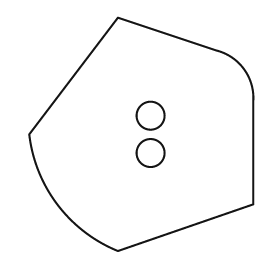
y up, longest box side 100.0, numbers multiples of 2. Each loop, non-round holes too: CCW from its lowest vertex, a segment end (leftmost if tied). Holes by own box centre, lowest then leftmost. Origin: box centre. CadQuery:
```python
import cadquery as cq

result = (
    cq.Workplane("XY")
    .moveTo(-10.0, -50.0)
    .lineTo(48.0, -30.0)
    .lineTo(48.0, 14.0)
    .threePointArc((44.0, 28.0), (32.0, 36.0))
    .lineTo(-10.0, 50.0)
    .lineTo(-48.0, 0.0)
    .threePointArc((-36.0, -30.0), (-10.0, -50.0))
    .close()
    .moveTo(4.0, -8.0)
    .circle(6.0)
    .moveTo(4.0, 8.0)
    .circle(6.0)
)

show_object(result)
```